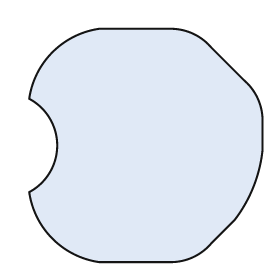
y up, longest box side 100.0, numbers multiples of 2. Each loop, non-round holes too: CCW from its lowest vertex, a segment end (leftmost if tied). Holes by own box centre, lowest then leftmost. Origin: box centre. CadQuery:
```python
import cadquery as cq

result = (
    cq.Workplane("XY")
    .moveTo(-20.0, -50.0)
    .lineTo(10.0, -50.0)
    .threePointArc((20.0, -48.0), (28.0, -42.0))
    .lineTo(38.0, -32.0)
    .threePointArc((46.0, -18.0), (50.0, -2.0))
    .lineTo(50.0, 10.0)
    .threePointArc((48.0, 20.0), (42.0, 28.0))
    .lineTo(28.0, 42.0)
    .threePointArc((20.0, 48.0), (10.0, 50.0))
    .lineTo(-20.0, 50.0)
    .threePointArc((-40.0, 40.0), (-50.0, 20.0))
    .threePointArc((-38.0, 0.0), (-50.0, -20.0))
    .threePointArc((-40.0, -40.0), (-20.0, -50.0))
    .close()
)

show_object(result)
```